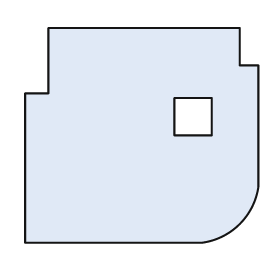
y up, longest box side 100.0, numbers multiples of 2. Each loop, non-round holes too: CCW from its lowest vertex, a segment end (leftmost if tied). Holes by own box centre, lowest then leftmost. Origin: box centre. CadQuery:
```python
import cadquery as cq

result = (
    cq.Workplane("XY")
    .moveTo(-50.0, -46.0)
    .lineTo(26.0, -46.0)
    .threePointArc((42.0, -38.0), (50.0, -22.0))
    .lineTo(50.0, 30.0)
    .lineTo(42.0, 30.0)
    .lineTo(42.0, 46.0)
    .lineTo(-40.0, 46.0)
    .lineTo(-40.0, 18.0)
    .lineTo(-50.0, 18.0)
    .close()
    .moveTo(14.0, 0.0)
    .lineTo(30.0, 0.0)
    .lineTo(30.0, 16.0)
    .lineTo(14.0, 16.0)
    .close()
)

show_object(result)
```